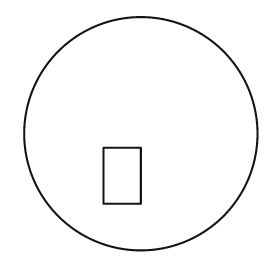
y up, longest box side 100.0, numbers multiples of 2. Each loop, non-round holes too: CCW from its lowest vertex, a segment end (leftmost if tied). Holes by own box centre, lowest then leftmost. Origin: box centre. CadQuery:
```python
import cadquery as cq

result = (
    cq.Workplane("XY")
    .moveTo(0.0, 0.0)
    .circle(50.0)
    .moveTo(-16.0, -30.0)
    .lineTo(0.0, -30.0)
    .lineTo(0.0, -6.0)
    .lineTo(-16.0, -6.0)
    .close()
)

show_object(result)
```